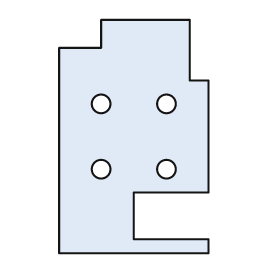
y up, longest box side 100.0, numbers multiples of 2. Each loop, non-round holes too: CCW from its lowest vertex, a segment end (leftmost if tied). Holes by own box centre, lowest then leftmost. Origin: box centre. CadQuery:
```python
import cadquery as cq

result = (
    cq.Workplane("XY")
    .moveTo(-32.0, -50.0)
    .lineTo(32.0, -50.0)
    .lineTo(32.0, -44.0)
    .lineTo(0.0, -44.0)
    .lineTo(0.0, -24.0)
    .lineTo(32.0, -24.0)
    .lineTo(32.0, 24.0)
    .lineTo(24.0, 24.0)
    .lineTo(24.0, 50.0)
    .lineTo(-14.0, 50.0)
    .lineTo(-14.0, 38.0)
    .lineTo(-32.0, 38.0)
    .close()
    .moveTo(-14.0, -14.0)
    .circle(4.0)
    .moveTo(14.0, -14.0)
    .circle(4.0)
    .moveTo(-14.0, 14.0)
    .circle(4.0)
    .moveTo(14.0, 14.0)
    .circle(4.0)
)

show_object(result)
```